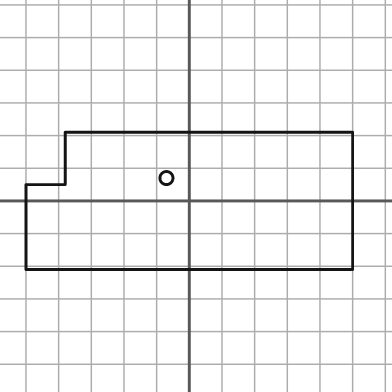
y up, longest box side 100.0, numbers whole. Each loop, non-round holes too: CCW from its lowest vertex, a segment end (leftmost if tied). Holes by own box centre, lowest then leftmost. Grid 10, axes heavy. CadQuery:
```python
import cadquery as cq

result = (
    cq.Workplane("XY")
    .moveTo(-50.0, -21.0)
    .lineTo(50.0, -21.0)
    .lineTo(50.0, 21.0)
    .lineTo(-38.0, 21.0)
    .lineTo(-38.0, 5.0)
    .lineTo(-50.0, 5.0)
    .close()
    .moveTo(-7.0, 7.0)
    .circle(2.0)
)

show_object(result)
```